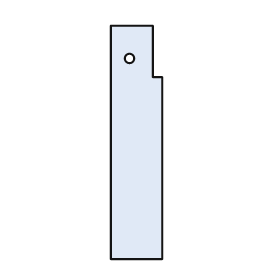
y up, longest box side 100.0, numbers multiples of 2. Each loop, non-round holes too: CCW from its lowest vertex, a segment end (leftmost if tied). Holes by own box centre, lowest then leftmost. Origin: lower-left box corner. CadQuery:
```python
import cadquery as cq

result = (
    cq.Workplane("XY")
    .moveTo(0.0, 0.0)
    .lineTo(22.0, 0.0)
    .lineTo(22.0, 78.0)
    .lineTo(18.0, 78.0)
    .lineTo(18.0, 100.0)
    .lineTo(0.0, 100.0)
    .close()
    .moveTo(8.0, 86.0)
    .circle(2.0)
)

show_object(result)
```